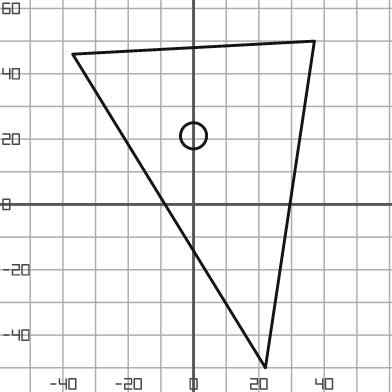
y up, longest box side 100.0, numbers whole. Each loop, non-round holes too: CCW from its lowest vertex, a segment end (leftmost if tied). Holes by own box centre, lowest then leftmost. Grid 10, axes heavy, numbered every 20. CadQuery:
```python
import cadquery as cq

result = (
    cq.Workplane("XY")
    .moveTo(22.0, -50.0)
    .lineTo(37.0, 50.0)
    .lineTo(-37.0, 46.0)
    .close()
    .moveTo(0.0, 21.0)
    .circle(4.0)
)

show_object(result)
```